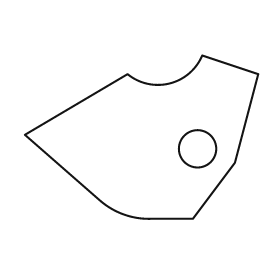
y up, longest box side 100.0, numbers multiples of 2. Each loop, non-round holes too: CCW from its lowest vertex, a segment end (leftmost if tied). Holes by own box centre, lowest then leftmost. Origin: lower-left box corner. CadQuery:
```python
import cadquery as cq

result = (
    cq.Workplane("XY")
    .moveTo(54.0, 0.0)
    .lineTo(72.0, 0.0)
    .lineTo(90.0, 24.0)
    .lineTo(100.0, 62.0)
    .lineTo(76.0, 70.0)
    .threePointArc((62.0, 58.0), (44.0, 62.0))
    .lineTo(0.0, 36.0)
    .lineTo(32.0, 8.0)
    .threePointArc((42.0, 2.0), (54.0, 0.0))
    .close()
    .moveTo(74.0, 30.0)
    .circle(8.0)
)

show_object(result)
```